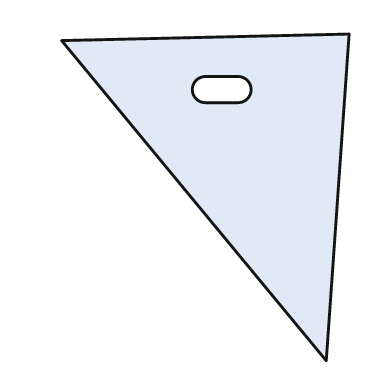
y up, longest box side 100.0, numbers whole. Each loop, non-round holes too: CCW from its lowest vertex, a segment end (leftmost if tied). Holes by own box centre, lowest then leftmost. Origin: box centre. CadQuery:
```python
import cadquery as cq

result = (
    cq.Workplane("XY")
    .moveTo(37.0, -50.0)
    .lineTo(44.0, 50.0)
    .lineTo(-44.0, 48.0)
    .close()
    .moveTo(0.0, 29.0)
    .lineTo(10.0, 29.0)
    .threePointArc((14.0, 33.0), (10.0, 37.0))
    .lineTo(0.0, 37.0)
    .threePointArc((-4.0, 33.0), (0.0, 29.0))
    .close()
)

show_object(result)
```